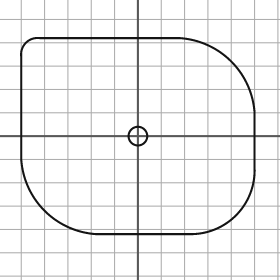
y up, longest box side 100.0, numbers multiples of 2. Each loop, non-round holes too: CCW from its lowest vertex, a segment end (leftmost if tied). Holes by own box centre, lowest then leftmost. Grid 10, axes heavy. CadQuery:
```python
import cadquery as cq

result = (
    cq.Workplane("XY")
    .moveTo(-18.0, -42.0)
    .lineTo(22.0, -42.0)
    .threePointArc((42.0, -34.0), (50.0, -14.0))
    .lineTo(50.0, 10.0)
    .threePointArc((40.0, 32.0), (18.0, 42.0))
    .lineTo(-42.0, 42.0)
    .threePointArc((-48.0, 40.0), (-50.0, 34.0))
    .lineTo(-50.0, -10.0)
    .threePointArc((-40.0, -32.0), (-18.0, -42.0))
    .close()
    .moveTo(0.0, 0.0)
    .circle(4.0)
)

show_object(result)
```